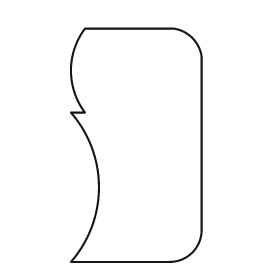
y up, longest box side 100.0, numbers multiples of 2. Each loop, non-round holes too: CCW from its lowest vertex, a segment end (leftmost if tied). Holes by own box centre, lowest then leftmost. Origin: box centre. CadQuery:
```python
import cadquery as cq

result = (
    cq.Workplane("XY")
    .moveTo(-28.0, -50.0)
    .lineTo(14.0, -50.0)
    .threePointArc((24.0, -46.0), (28.0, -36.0))
    .lineTo(28.0, 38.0)
    .threePointArc((24.0, 46.0), (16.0, 50.0))
    .lineTo(-22.0, 50.0)
    .threePointArc((-28.0, 32.0), (-22.0, 14.0))
    .lineTo(-28.0, 14.0)
    .threePointArc((-16.0, -18.0), (-28.0, -50.0))
    .close()
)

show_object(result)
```